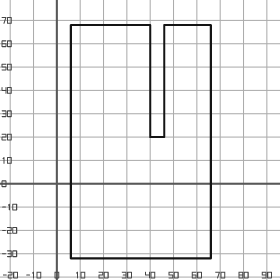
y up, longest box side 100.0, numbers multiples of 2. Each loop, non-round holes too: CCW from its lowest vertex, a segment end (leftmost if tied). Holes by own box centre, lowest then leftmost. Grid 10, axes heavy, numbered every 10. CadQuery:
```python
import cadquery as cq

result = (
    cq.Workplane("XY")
    .moveTo(6.0, -32.0)
    .lineTo(66.0, -32.0)
    .lineTo(66.0, 68.0)
    .lineTo(46.0, 68.0)
    .lineTo(46.0, 20.0)
    .lineTo(40.0, 20.0)
    .lineTo(40.0, 68.0)
    .lineTo(6.0, 68.0)
    .close()
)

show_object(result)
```